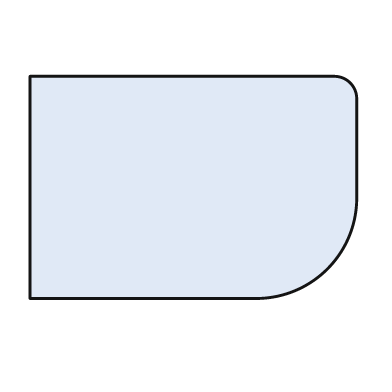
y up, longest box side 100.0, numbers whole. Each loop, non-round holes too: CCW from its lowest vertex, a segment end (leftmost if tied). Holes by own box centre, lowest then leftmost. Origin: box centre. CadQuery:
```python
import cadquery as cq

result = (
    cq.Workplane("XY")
    .moveTo(-50.0, -34.0)
    .lineTo(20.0, -34.0)
    .threePointArc((41.0, -25.0), (50.0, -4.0))
    .lineTo(50.0, 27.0)
    .threePointArc((48.0, 32.0), (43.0, 34.0))
    .lineTo(-50.0, 34.0)
    .close()
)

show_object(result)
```